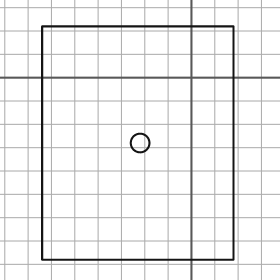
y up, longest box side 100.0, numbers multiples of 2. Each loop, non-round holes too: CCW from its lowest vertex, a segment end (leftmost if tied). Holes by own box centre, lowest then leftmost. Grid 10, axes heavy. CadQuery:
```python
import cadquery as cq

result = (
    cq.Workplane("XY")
    .moveTo(-64.0, -78.0)
    .lineTo(18.0, -78.0)
    .lineTo(18.0, 22.0)
    .lineTo(-64.0, 22.0)
    .close()
    .moveTo(-22.0, -28.0)
    .circle(4.0)
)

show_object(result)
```